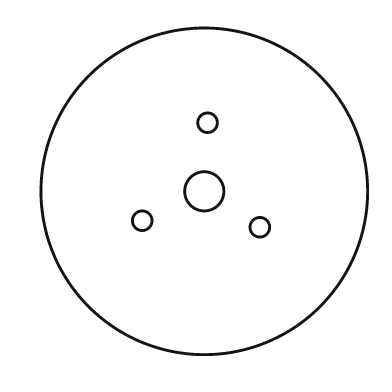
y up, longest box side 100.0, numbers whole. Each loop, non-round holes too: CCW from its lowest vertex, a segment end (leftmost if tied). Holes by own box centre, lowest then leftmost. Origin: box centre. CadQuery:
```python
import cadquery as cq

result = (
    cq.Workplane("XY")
    .moveTo(0.0, 0.0)
    .circle(50.0)
    .moveTo(17.0, -11.0)
    .circle(3.0)
    .moveTo(-19.0, -9.0)
    .circle(3.0)
    .moveTo(0.0, 0.0)
    .circle(6.0)
    .moveTo(1.0, 21.0)
    .circle(3.0)
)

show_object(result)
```